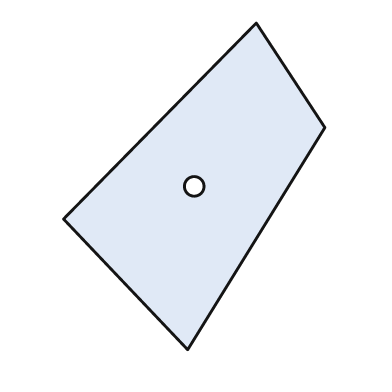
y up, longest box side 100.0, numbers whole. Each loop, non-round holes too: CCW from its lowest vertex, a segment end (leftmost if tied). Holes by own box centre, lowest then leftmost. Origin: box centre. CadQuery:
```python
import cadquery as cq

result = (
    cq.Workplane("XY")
    .moveTo(-2.0, -50.0)
    .lineTo(40.0, 18.0)
    .lineTo(19.0, 50.0)
    .lineTo(-40.0, -10.0)
    .close()
    .moveTo(0.0, 0.0)
    .circle(3.0)
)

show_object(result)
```